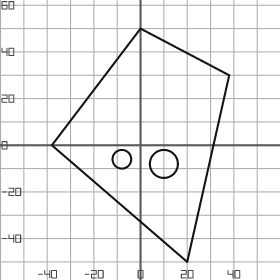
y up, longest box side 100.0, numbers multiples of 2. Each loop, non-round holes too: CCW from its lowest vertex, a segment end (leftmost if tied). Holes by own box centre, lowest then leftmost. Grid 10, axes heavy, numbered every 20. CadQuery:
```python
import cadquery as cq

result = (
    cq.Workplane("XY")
    .moveTo(20.0, -50.0)
    .lineTo(38.0, 30.0)
    .lineTo(0.0, 50.0)
    .lineTo(-38.0, 0.0)
    .close()
    .moveTo(10.0, -8.0)
    .circle(6.0)
    .moveTo(-8.0, -6.0)
    .circle(4.0)
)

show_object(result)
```